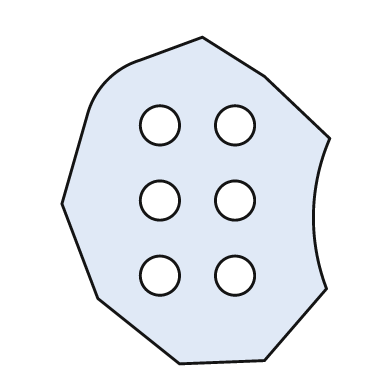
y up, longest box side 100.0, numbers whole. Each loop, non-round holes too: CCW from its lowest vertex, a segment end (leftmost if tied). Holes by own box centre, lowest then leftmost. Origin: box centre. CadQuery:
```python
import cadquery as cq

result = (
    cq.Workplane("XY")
    .moveTo(-5.0, -50.0)
    .lineTo(21.0, -49.0)
    .lineTo(40.0, -27.0)
    .threePointArc((36.0, -4.0), (41.0, 19.0))
    .lineTo(21.0, 38.0)
    .lineTo(2.0, 50.0)
    .lineTo(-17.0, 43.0)
    .threePointArc((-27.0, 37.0), (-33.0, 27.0))
    .lineTo(-41.0, -1.0)
    .lineTo(-30.0, -30.0)
    .close()
    .moveTo(-11.0, -23.0)
    .circle(6.0)
    .moveTo(12.0, -23.0)
    .circle(6.0)
    .moveTo(-11.0, 0.0)
    .circle(6.0)
    .moveTo(12.0, 0.0)
    .circle(6.0)
    .moveTo(-11.0, 23.0)
    .circle(6.0)
    .moveTo(12.0, 23.0)
    .circle(6.0)
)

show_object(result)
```